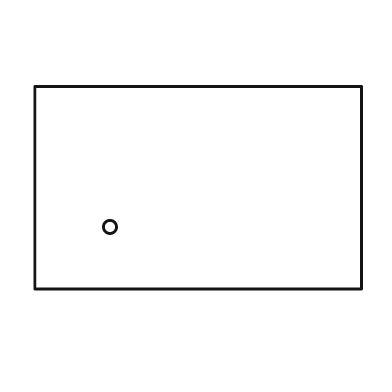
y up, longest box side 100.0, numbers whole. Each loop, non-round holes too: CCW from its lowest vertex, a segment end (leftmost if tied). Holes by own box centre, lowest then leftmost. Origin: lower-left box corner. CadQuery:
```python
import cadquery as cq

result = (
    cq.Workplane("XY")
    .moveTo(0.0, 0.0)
    .lineTo(100.0, 0.0)
    .lineTo(100.0, 62.0)
    .lineTo(0.0, 62.0)
    .close()
    .moveTo(23.0, 19.0)
    .circle(2.0)
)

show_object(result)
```